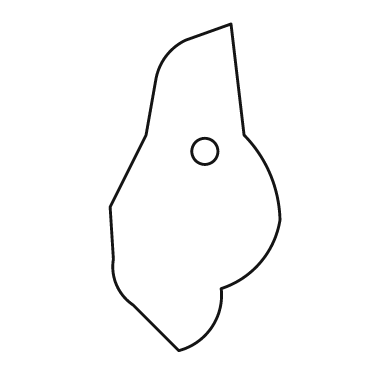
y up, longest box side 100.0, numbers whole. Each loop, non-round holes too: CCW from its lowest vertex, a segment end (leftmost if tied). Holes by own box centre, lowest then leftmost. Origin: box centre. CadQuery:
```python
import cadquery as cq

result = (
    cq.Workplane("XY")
    .moveTo(-5.0, -50.0)
    .threePointArc((5.0, -43.0), (8.0, -31.0))
    .threePointArc((20.0, -23.0), (26.0, -10.0))
    .threePointArc((23.0, 4.0), (15.0, 16.0))
    .lineTo(11.0, 50.0)
    .lineTo(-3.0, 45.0)
    .threePointArc((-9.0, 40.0), (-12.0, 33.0))
    .lineTo(-15.0, 16.0)
    .lineTo(-26.0, -6.0)
    .lineTo(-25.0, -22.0)
    .threePointArc((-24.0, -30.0), (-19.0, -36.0))
    .close()
    .moveTo(3.0, 11.0)
    .circle(4.0)
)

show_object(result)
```